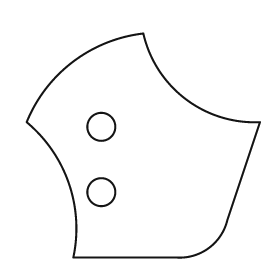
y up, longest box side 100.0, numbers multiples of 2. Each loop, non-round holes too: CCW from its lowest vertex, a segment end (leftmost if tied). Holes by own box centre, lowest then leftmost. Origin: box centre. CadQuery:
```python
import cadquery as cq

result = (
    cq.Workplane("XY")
    .moveTo(-30.0, -48.0)
    .lineTo(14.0, -48.0)
    .threePointArc((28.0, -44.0), (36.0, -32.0))
    .lineTo(50.0, 10.0)
    .threePointArc((18.0, 20.0), (0.0, 48.0))
    .threePointArc((-30.0, 36.0), (-50.0, 10.0))
    .threePointArc((-32.0, -16.0), (-30.0, -48.0))
    .close()
    .moveTo(-18.0, -20.0)
    .circle(6.0)
    .moveTo(-18.0, 8.0)
    .circle(6.0)
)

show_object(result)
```